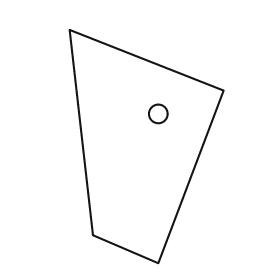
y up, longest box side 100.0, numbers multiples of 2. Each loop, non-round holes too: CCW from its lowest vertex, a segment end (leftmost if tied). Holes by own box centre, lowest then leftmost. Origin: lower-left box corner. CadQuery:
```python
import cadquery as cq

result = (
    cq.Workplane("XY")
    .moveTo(38.0, 0.0)
    .lineTo(66.0, 74.0)
    .lineTo(0.0, 100.0)
    .lineTo(10.0, 12.0)
    .close()
    .moveTo(38.0, 64.0)
    .circle(4.0)
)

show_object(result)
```